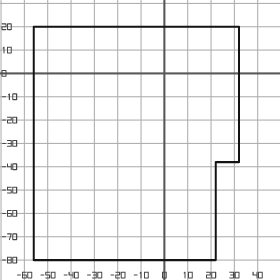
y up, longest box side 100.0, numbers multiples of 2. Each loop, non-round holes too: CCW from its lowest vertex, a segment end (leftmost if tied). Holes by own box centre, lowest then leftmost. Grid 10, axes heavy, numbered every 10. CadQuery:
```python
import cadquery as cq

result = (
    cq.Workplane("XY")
    .moveTo(-56.0, -80.0)
    .lineTo(22.0, -80.0)
    .lineTo(22.0, -38.0)
    .lineTo(32.0, -38.0)
    .lineTo(32.0, 20.0)
    .lineTo(-56.0, 20.0)
    .close()
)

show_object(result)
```